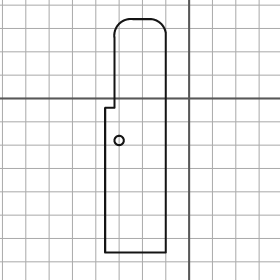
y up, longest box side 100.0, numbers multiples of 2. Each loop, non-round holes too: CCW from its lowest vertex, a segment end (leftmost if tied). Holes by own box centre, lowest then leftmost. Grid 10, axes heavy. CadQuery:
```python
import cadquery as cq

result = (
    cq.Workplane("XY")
    .moveTo(-36.0, -66.0)
    .lineTo(-10.0, -66.0)
    .lineTo(-10.0, 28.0)
    .threePointArc((-12.0, 32.0), (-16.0, 34.0))
    .lineTo(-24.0, 34.0)
    .threePointArc((-30.0, 32.0), (-32.0, 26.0))
    .lineTo(-32.0, -4.0)
    .lineTo(-36.0, -4.0)
    .close()
    .moveTo(-30.0, -18.0)
    .circle(2.0)
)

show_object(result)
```